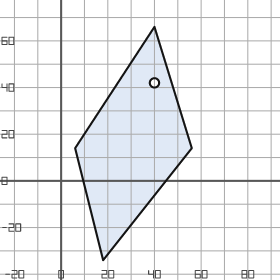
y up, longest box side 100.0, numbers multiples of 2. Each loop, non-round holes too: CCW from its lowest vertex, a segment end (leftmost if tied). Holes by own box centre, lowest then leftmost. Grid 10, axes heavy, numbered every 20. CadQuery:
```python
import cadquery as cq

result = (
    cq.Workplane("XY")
    .moveTo(18.0, -34.0)
    .lineTo(56.0, 14.0)
    .lineTo(40.0, 66.0)
    .lineTo(6.0, 14.0)
    .close()
    .moveTo(40.0, 42.0)
    .circle(2.0)
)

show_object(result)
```